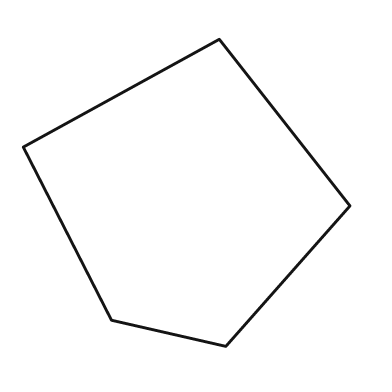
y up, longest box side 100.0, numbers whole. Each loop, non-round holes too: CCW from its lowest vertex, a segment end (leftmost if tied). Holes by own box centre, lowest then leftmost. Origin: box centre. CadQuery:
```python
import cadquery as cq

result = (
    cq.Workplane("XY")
    .moveTo(12.0, -47.0)
    .lineTo(50.0, -4.0)
    .lineTo(10.0, 47.0)
    .lineTo(-50.0, 14.0)
    .lineTo(-23.0, -39.0)
    .close()
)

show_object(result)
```